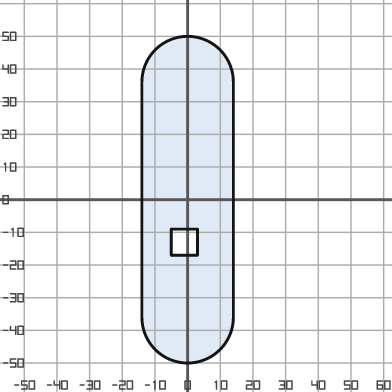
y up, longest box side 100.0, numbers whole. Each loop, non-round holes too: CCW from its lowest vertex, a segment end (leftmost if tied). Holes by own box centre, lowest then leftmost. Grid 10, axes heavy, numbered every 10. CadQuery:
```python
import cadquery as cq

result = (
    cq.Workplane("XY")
    .moveTo(-14.0, -36.0)
    .threePointArc((0.0, -50.0), (14.0, -36.0))
    .lineTo(14.0, 36.0)
    .threePointArc((0.0, 50.0), (-14.0, 36.0))
    .close()
    .moveTo(-5.0, -17.0)
    .lineTo(3.0, -17.0)
    .lineTo(3.0, -9.0)
    .lineTo(-5.0, -9.0)
    .close()
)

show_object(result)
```